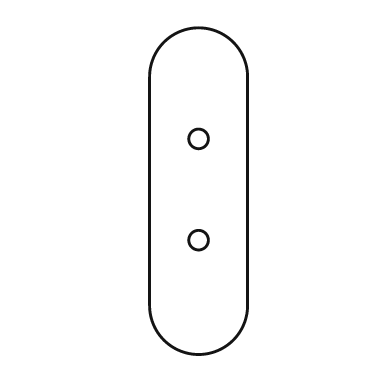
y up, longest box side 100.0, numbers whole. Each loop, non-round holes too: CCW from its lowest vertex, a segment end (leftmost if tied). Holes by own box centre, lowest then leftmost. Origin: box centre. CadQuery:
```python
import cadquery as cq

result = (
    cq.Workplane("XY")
    .moveTo(-15.0, -35.0)
    .threePointArc((0.0, -50.0), (15.0, -35.0))
    .lineTo(15.0, 35.0)
    .threePointArc((0.0, 50.0), (-15.0, 35.0))
    .close()
    .moveTo(0.0, -15.0)
    .circle(3.0)
    .moveTo(0.0, 16.0)
    .circle(3.0)
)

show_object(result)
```